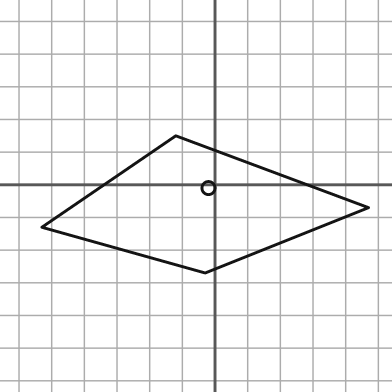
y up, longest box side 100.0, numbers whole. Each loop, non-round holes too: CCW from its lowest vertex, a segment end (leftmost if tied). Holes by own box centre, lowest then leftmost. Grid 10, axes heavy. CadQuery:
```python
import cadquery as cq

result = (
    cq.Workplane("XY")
    .moveTo(-3.0, -27.0)
    .lineTo(47.0, -7.0)
    .lineTo(-12.0, 15.0)
    .lineTo(-53.0, -13.0)
    .close()
    .moveTo(-2.0, -1.0)
    .circle(2.0)
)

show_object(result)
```